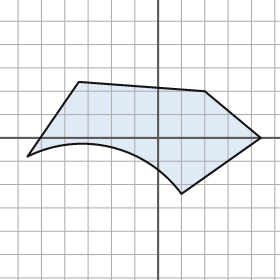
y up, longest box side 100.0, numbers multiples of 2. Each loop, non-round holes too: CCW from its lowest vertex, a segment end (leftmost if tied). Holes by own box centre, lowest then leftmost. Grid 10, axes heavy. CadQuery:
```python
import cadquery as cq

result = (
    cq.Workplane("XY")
    .moveTo(10.0, -24.0)
    .lineTo(44.0, 0.0)
    .lineTo(20.0, 20.0)
    .lineTo(-34.0, 24.0)
    .lineTo(-56.0, -8.0)
    .threePointArc((-20.0, -4.0), (10.0, -24.0))
    .close()
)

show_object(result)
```